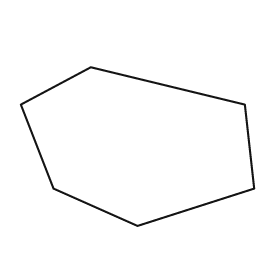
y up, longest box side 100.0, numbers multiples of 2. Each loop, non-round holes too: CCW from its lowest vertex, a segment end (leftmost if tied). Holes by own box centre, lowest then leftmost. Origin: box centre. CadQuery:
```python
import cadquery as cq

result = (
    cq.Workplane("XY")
    .moveTo(0.0, -34.0)
    .lineTo(50.0, -18.0)
    .lineTo(46.0, 18.0)
    .lineTo(-20.0, 34.0)
    .lineTo(-50.0, 18.0)
    .lineTo(-36.0, -18.0)
    .close()
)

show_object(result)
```